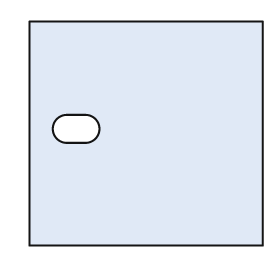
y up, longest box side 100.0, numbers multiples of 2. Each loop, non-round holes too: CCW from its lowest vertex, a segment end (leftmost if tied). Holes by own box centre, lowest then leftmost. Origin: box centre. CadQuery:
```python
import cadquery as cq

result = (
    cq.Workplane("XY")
    .moveTo(-50.0, -48.0)
    .lineTo(50.0, -48.0)
    .lineTo(50.0, 48.0)
    .lineTo(-50.0, 48.0)
    .close()
    .moveTo(-34.0, -4.0)
    .lineTo(-26.0, -4.0)
    .threePointArc((-20.0, 2.0), (-26.0, 8.0))
    .lineTo(-34.0, 8.0)
    .threePointArc((-40.0, 2.0), (-34.0, -4.0))
    .close()
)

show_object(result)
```